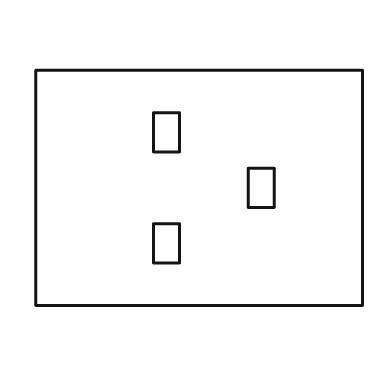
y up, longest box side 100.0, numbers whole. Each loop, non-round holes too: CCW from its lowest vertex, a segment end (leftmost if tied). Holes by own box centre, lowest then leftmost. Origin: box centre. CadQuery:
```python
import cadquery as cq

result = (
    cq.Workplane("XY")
    .moveTo(-50.0, -36.0)
    .lineTo(50.0, -36.0)
    .lineTo(50.0, 36.0)
    .lineTo(-50.0, 36.0)
    .close()
    .moveTo(-14.0, -23.0)
    .lineTo(-6.0, -23.0)
    .lineTo(-6.0, -11.0)
    .lineTo(-14.0, -11.0)
    .close()
    .moveTo(15.0, -6.0)
    .lineTo(23.0, -6.0)
    .lineTo(23.0, 6.0)
    .lineTo(15.0, 6.0)
    .close()
    .moveTo(-14.0, 11.0)
    .lineTo(-6.0, 11.0)
    .lineTo(-6.0, 23.0)
    .lineTo(-14.0, 23.0)
    .close()
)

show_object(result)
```